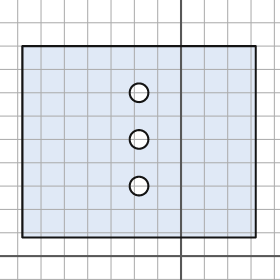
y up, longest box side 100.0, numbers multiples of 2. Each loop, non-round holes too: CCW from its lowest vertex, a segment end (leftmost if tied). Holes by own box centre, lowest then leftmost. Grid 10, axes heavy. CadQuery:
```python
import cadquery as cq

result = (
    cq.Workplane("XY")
    .moveTo(-68.0, 8.0)
    .lineTo(32.0, 8.0)
    .lineTo(32.0, 90.0)
    .lineTo(-68.0, 90.0)
    .close()
    .moveTo(-18.0, 30.0)
    .circle(4.0)
    .moveTo(-18.0, 50.0)
    .circle(4.0)
    .moveTo(-18.0, 70.0)
    .circle(4.0)
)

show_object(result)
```